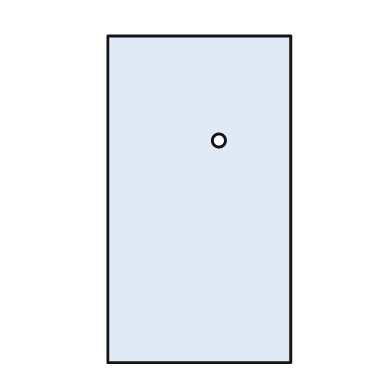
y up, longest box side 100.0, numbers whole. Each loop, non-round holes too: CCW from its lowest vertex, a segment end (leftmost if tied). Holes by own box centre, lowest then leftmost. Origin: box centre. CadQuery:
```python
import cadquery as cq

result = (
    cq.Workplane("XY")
    .moveTo(-28.0, -50.0)
    .lineTo(28.0, -50.0)
    .lineTo(28.0, 50.0)
    .lineTo(-28.0, 50.0)
    .close()
    .moveTo(6.0, 18.0)
    .circle(2.0)
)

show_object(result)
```